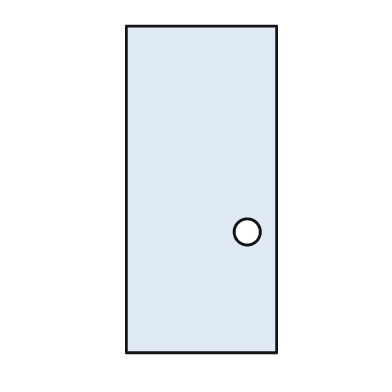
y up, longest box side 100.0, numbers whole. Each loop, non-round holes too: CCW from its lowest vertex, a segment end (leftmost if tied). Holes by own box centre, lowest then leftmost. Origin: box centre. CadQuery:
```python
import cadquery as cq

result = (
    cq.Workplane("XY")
    .moveTo(-23.0, -50.0)
    .lineTo(23.0, -50.0)
    .lineTo(23.0, 50.0)
    .lineTo(-23.0, 50.0)
    .close()
    .moveTo(14.0, -13.0)
    .circle(4.0)
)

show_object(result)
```